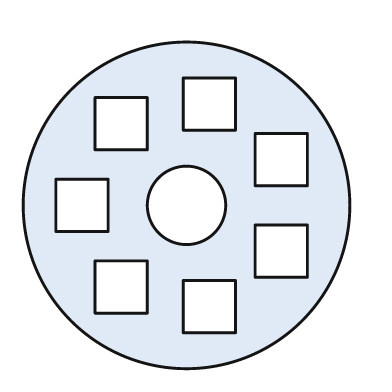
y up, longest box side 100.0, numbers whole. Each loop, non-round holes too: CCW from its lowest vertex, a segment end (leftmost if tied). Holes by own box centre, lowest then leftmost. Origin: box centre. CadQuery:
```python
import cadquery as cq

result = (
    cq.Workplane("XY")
    .moveTo(0.0, 0.0)
    .circle(50.0)
    .moveTo(-1.0, -39.0)
    .lineTo(15.0, -39.0)
    .lineTo(15.0, -23.0)
    .lineTo(-1.0, -23.0)
    .close()
    .moveTo(-28.0, -33.0)
    .lineTo(-12.0, -33.0)
    .lineTo(-12.0, -17.0)
    .lineTo(-28.0, -17.0)
    .close()
    .moveTo(21.0, -22.0)
    .lineTo(37.0, -22.0)
    .lineTo(37.0, -6.0)
    .lineTo(21.0, -6.0)
    .close()
    .moveTo(-40.0, -8.0)
    .lineTo(-24.0, -8.0)
    .lineTo(-24.0, 8.0)
    .lineTo(-40.0, 8.0)
    .close()
    .moveTo(0.0, 0.0)
    .circle(12.0)
    .moveTo(21.0, 6.0)
    .lineTo(37.0, 6.0)
    .lineTo(37.0, 22.0)
    .lineTo(21.0, 22.0)
    .close()
    .moveTo(-28.0, 17.0)
    .lineTo(-12.0, 17.0)
    .lineTo(-12.0, 33.0)
    .lineTo(-28.0, 33.0)
    .close()
    .moveTo(-1.0, 23.0)
    .lineTo(15.0, 23.0)
    .lineTo(15.0, 39.0)
    .lineTo(-1.0, 39.0)
    .close()
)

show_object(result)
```